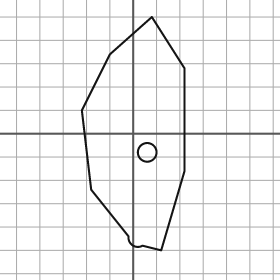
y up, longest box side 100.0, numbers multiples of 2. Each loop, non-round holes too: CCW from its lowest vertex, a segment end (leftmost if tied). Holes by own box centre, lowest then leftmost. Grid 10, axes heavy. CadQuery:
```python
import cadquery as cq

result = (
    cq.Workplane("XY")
    .moveTo(12.0, -50.0)
    .lineTo(22.0, -16.0)
    .lineTo(22.0, 28.0)
    .lineTo(8.0, 50.0)
    .lineTo(-10.0, 34.0)
    .lineTo(-22.0, 10.0)
    .lineTo(-18.0, -24.0)
    .lineTo(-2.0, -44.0)
    .threePointArc((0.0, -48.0), (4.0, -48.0))
    .close()
    .moveTo(6.0, -8.0)
    .circle(4.0)
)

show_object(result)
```